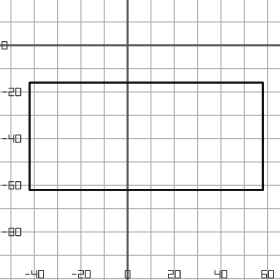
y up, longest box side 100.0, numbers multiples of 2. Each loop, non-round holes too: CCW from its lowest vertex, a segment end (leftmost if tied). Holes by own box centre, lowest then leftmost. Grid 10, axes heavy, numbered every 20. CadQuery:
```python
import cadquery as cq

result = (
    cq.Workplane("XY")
    .moveTo(-42.0, -62.0)
    .lineTo(58.0, -62.0)
    .lineTo(58.0, -16.0)
    .lineTo(-42.0, -16.0)
    .close()
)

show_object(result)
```